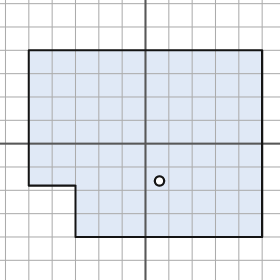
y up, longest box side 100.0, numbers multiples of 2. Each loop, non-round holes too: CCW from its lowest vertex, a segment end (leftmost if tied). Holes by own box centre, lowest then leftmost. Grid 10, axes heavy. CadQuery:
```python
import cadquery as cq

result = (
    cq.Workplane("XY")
    .moveTo(-30.0, -40.0)
    .lineTo(50.0, -40.0)
    .lineTo(50.0, 40.0)
    .lineTo(-50.0, 40.0)
    .lineTo(-50.0, -18.0)
    .lineTo(-30.0, -18.0)
    .close()
    .moveTo(6.0, -16.0)
    .circle(2.0)
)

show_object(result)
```